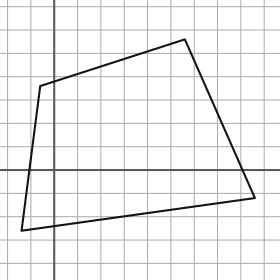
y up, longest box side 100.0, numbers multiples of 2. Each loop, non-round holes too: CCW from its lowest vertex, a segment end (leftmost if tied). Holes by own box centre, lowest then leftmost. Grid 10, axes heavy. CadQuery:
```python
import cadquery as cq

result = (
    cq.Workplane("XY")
    .moveTo(-14.0, -26.0)
    .lineTo(86.0, -12.0)
    .lineTo(56.0, 56.0)
    .lineTo(-6.0, 36.0)
    .close()
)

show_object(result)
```